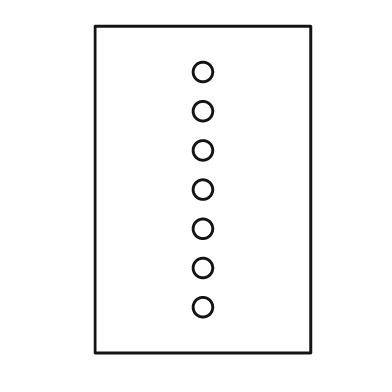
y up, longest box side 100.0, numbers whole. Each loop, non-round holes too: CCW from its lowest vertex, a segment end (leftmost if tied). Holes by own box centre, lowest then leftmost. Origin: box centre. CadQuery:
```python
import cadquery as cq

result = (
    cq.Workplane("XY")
    .moveTo(-33.0, -50.0)
    .lineTo(33.0, -50.0)
    .lineTo(33.0, 50.0)
    .lineTo(-33.0, 50.0)
    .close()
    .moveTo(0.0, -36.0)
    .circle(3.0)
    .moveTo(0.0, -24.0)
    .circle(3.0)
    .moveTo(0.0, -12.0)
    .circle(3.0)
    .moveTo(0.0, 0.0)
    .circle(3.0)
    .moveTo(0.0, 12.0)
    .circle(3.0)
    .moveTo(0.0, 24.0)
    .circle(3.0)
    .moveTo(0.0, 36.0)
    .circle(3.0)
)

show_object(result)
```